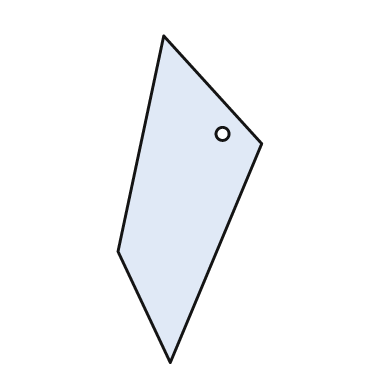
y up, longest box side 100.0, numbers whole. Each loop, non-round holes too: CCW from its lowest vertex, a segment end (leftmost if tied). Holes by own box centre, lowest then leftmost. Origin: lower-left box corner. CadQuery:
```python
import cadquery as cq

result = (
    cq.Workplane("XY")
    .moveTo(16.0, 0.0)
    .lineTo(44.0, 67.0)
    .lineTo(14.0, 100.0)
    .lineTo(0.0, 34.0)
    .close()
    .moveTo(32.0, 70.0)
    .circle(2.0)
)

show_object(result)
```